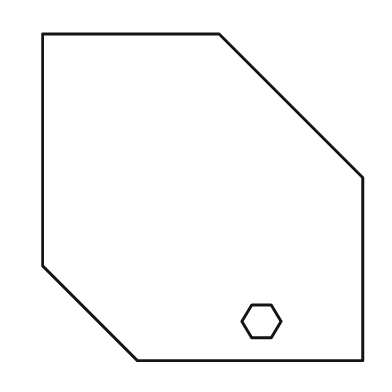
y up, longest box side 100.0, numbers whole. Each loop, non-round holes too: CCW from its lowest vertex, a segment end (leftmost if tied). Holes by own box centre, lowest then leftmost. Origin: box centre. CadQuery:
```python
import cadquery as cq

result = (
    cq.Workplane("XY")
    .moveTo(-20.0, -50.0)
    .lineTo(49.0, -50.0)
    .lineTo(49.0, 6.0)
    .lineTo(5.0, 50.0)
    .lineTo(-49.0, 50.0)
    .lineTo(-49.0, -21.0)
    .close()
    .moveTo(15.0, -43.0)
    .lineTo(21.0, -43.0)
    .lineTo(24.0, -38.0)
    .lineTo(21.0, -33.0)
    .lineTo(15.0, -33.0)
    .lineTo(12.0, -38.0)
    .close()
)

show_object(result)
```